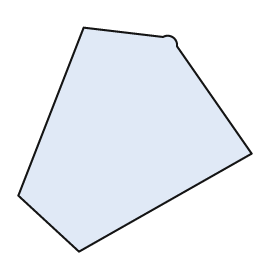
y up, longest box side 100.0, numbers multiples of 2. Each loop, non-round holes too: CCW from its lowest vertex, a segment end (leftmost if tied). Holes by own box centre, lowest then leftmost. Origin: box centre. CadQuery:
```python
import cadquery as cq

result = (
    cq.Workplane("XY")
    .moveTo(-24.0, -48.0)
    .lineTo(50.0, -6.0)
    .lineTo(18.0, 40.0)
    .threePointArc((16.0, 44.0), (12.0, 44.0))
    .lineTo(-22.0, 48.0)
    .lineTo(-50.0, -24.0)
    .close()
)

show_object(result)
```